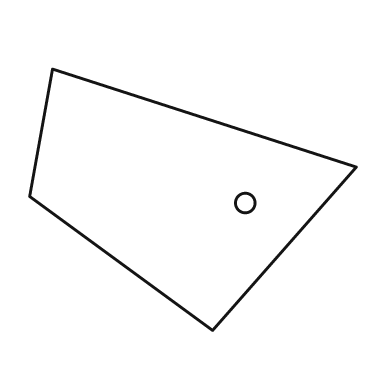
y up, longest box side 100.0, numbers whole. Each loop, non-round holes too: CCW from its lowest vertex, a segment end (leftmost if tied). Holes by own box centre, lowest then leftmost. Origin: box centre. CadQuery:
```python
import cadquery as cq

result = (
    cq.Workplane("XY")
    .moveTo(6.0, -40.0)
    .lineTo(50.0, 10.0)
    .lineTo(-43.0, 40.0)
    .lineTo(-50.0, 1.0)
    .close()
    .moveTo(16.0, -1.0)
    .circle(3.0)
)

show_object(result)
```